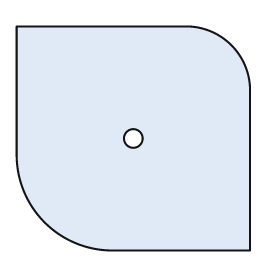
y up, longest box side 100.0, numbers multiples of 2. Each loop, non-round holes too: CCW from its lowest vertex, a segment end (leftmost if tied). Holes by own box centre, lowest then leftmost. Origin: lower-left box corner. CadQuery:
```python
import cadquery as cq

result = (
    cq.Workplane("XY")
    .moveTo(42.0, 0.0)
    .lineTo(100.0, 0.0)
    .lineTo(100.0, 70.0)
    .threePointArc((92.0, 88.0), (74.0, 96.0))
    .lineTo(0.0, 96.0)
    .lineTo(0.0, 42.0)
    .threePointArc((12.0, 12.0), (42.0, 0.0))
    .close()
    .moveTo(50.0, 48.0)
    .circle(4.0)
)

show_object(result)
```